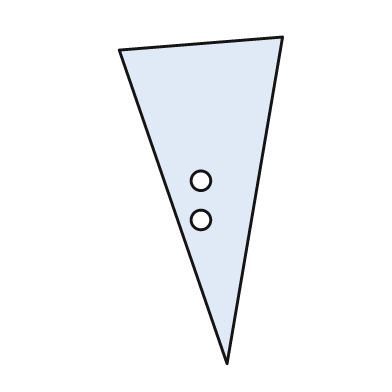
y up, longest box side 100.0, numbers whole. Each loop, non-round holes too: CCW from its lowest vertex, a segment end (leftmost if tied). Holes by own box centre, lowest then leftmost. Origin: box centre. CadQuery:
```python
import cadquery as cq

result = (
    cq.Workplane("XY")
    .moveTo(8.0, -50.0)
    .lineTo(25.0, 50.0)
    .lineTo(-25.0, 46.0)
    .close()
    .moveTo(0.0, -6.0)
    .circle(3.0)
    .moveTo(0.0, 6.0)
    .circle(3.0)
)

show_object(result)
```